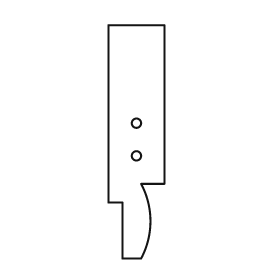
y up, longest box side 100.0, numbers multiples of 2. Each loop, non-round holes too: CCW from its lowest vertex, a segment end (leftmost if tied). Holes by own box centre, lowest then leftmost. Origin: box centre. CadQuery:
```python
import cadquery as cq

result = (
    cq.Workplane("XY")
    .moveTo(-6.0, -50.0)
    .lineTo(2.0, -50.0)
    .threePointArc((6.0, -34.0), (2.0, -18.0))
    .lineTo(12.0, -18.0)
    .lineTo(12.0, 50.0)
    .lineTo(-12.0, 50.0)
    .lineTo(-12.0, -26.0)
    .lineTo(-6.0, -26.0)
    .close()
    .moveTo(0.0, -6.0)
    .circle(2.0)
    .moveTo(0.0, 8.0)
    .circle(2.0)
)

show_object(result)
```